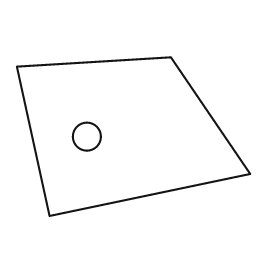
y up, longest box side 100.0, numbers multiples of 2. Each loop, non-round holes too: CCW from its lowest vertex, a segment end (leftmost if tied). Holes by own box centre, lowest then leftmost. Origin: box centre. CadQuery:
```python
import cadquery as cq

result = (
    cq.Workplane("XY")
    .moveTo(-36.0, -34.0)
    .lineTo(50.0, -16.0)
    .lineTo(16.0, 34.0)
    .lineTo(-50.0, 30.0)
    .close()
    .moveTo(-20.0, 0.0)
    .circle(6.0)
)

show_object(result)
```